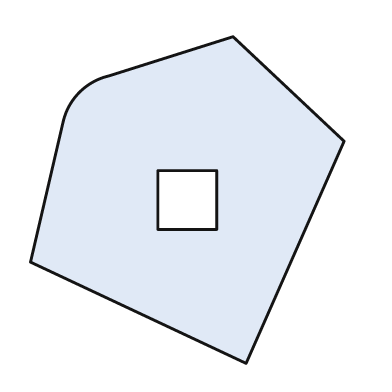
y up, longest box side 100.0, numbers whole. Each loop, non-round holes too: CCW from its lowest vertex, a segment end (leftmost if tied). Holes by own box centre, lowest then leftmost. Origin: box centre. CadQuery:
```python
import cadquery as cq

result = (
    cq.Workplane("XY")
    .moveTo(18.0, -50.0)
    .lineTo(48.0, 18.0)
    .lineTo(14.0, 50.0)
    .lineTo(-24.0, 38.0)
    .threePointArc((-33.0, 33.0), (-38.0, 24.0))
    .lineTo(-48.0, -19.0)
    .close()
    .moveTo(-9.0, -9.0)
    .lineTo(9.0, -9.0)
    .lineTo(9.0, 9.0)
    .lineTo(-9.0, 9.0)
    .close()
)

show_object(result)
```